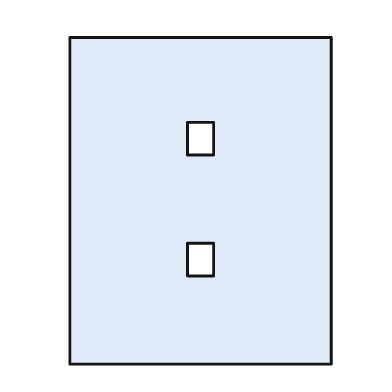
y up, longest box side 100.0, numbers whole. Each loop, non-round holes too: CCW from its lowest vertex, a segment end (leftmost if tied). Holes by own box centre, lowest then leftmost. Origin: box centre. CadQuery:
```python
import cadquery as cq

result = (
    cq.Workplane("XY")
    .moveTo(-40.0, -50.0)
    .lineTo(40.0, -50.0)
    .lineTo(40.0, 50.0)
    .lineTo(-40.0, 50.0)
    .close()
    .moveTo(-4.0, -23.0)
    .lineTo(4.0, -23.0)
    .lineTo(4.0, -13.0)
    .lineTo(-4.0, -13.0)
    .close()
    .moveTo(-4.0, 14.0)
    .lineTo(4.0, 14.0)
    .lineTo(4.0, 24.0)
    .lineTo(-4.0, 24.0)
    .close()
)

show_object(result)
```